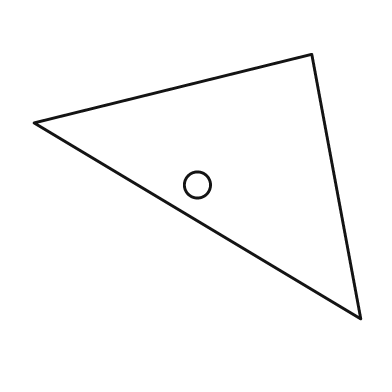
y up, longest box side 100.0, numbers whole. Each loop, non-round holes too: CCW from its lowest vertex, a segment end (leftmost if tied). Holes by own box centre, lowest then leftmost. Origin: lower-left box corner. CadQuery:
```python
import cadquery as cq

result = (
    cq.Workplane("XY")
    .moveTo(100.0, 0.0)
    .lineTo(85.0, 81.0)
    .lineTo(0.0, 60.0)
    .close()
    .moveTo(50.0, 41.0)
    .circle(4.0)
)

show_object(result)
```